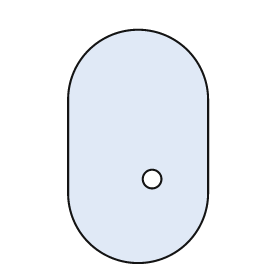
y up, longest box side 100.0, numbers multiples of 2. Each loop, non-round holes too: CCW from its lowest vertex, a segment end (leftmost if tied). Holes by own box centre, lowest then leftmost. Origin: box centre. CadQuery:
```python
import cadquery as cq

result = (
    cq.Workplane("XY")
    .moveTo(-30.0, -20.0)
    .threePointArc((0.0, -50.0), (30.0, -20.0))
    .lineTo(30.0, 20.0)
    .threePointArc((0.0, 50.0), (-30.0, 20.0))
    .close()
    .moveTo(6.0, -14.0)
    .circle(4.0)
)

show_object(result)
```